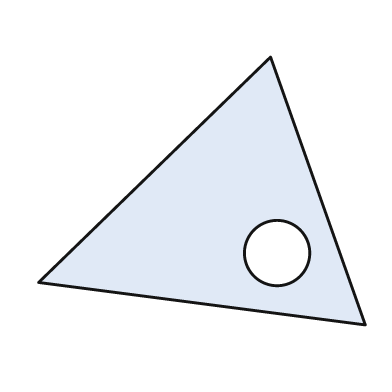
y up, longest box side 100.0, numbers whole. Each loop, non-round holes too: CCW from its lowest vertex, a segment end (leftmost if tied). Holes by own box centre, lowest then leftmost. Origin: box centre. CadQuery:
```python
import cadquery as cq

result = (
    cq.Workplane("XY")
    .moveTo(50.0, -41.0)
    .lineTo(21.0, 41.0)
    .lineTo(-50.0, -28.0)
    .close()
    .moveTo(23.0, -19.0)
    .circle(10.0)
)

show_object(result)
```